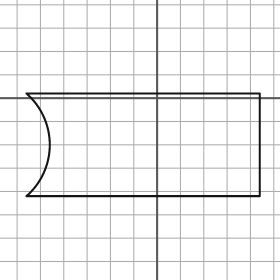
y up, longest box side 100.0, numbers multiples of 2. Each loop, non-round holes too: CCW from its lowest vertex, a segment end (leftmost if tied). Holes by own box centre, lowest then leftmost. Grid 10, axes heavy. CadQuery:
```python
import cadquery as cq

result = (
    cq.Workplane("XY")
    .moveTo(-56.0, -42.0)
    .lineTo(44.0, -42.0)
    .lineTo(44.0, 2.0)
    .lineTo(-56.0, 2.0)
    .threePointArc((-46.0, -20.0), (-56.0, -42.0))
    .close()
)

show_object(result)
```